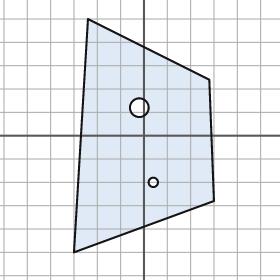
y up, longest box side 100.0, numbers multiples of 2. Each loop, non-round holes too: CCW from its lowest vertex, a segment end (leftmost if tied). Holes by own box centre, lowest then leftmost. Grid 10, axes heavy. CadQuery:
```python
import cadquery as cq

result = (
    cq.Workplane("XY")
    .moveTo(-30.0, -50.0)
    .lineTo(30.0, -28.0)
    .lineTo(28.0, 24.0)
    .lineTo(-24.0, 50.0)
    .close()
    .moveTo(4.0, -20.0)
    .circle(2.0)
    .moveTo(-2.0, 12.0)
    .circle(4.0)
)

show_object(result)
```